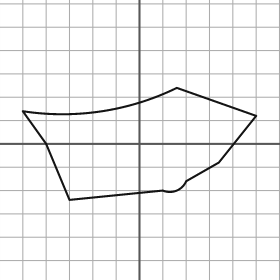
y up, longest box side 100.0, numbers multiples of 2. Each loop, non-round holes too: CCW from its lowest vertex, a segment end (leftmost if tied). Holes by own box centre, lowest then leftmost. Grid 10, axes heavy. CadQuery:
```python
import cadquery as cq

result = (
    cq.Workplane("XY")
    .moveTo(-30.0, -24.0)
    .lineTo(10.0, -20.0)
    .threePointArc((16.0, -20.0), (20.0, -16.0))
    .lineTo(34.0, -8.0)
    .lineTo(50.0, 12.0)
    .lineTo(16.0, 24.0)
    .threePointArc((-16.0, 14.0), (-50.0, 14.0))
    .lineTo(-40.0, 0.0)
    .close()
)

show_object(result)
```